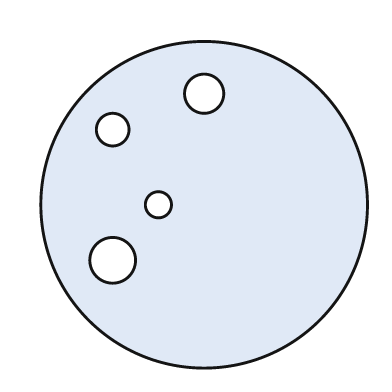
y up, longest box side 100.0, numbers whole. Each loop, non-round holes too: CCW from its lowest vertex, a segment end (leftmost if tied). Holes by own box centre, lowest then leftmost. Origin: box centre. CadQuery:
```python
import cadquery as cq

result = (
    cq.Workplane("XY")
    .moveTo(0.0, 0.0)
    .circle(50.0)
    .moveTo(-28.0, -17.0)
    .circle(7.0)
    .moveTo(-14.0, 0.0)
    .circle(4.0)
    .moveTo(-28.0, 23.0)
    .circle(5.0)
    .moveTo(0.0, 34.0)
    .circle(6.0)
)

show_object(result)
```